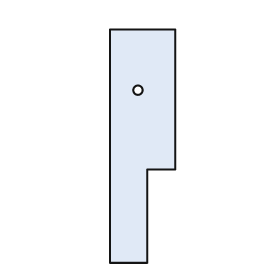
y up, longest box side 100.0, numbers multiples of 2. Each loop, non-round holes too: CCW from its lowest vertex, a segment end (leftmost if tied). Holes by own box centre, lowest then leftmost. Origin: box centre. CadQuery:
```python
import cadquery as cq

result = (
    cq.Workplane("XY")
    .moveTo(-14.0, -50.0)
    .lineTo(2.0, -50.0)
    .lineTo(2.0, -10.0)
    .lineTo(14.0, -10.0)
    .lineTo(14.0, 50.0)
    .lineTo(-14.0, 50.0)
    .close()
    .moveTo(-2.0, 24.0)
    .circle(2.0)
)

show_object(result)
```